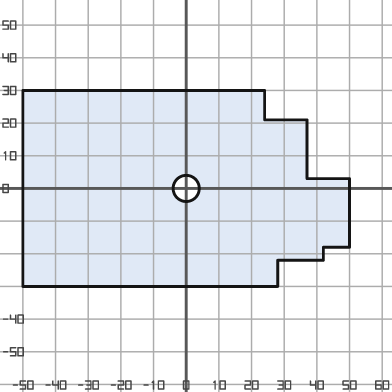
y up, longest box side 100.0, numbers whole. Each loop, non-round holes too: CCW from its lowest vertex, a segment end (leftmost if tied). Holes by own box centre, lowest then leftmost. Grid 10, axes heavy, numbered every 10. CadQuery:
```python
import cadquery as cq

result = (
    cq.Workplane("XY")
    .moveTo(-50.0, -30.0)
    .lineTo(28.0, -30.0)
    .lineTo(28.0, -22.0)
    .lineTo(42.0, -22.0)
    .lineTo(42.0, -18.0)
    .lineTo(50.0, -18.0)
    .lineTo(50.0, 3.0)
    .lineTo(37.0, 3.0)
    .lineTo(37.0, 21.0)
    .lineTo(24.0, 21.0)
    .lineTo(24.0, 30.0)
    .lineTo(-50.0, 30.0)
    .close()
    .moveTo(0.0, 0.0)
    .circle(4.0)
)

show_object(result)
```